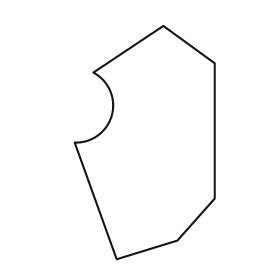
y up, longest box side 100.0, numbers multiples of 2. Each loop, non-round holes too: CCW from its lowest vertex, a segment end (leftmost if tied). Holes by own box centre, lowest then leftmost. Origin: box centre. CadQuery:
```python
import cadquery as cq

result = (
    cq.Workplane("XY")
    .moveTo(-12.0, -50.0)
    .lineTo(14.0, -42.0)
    .lineTo(30.0, -24.0)
    .lineTo(30.0, 34.0)
    .lineTo(8.0, 50.0)
    .lineTo(-22.0, 30.0)
    .threePointArc((-14.0, 12.0), (-30.0, 0.0))
    .close()
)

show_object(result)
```